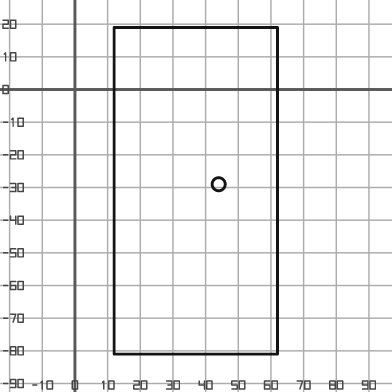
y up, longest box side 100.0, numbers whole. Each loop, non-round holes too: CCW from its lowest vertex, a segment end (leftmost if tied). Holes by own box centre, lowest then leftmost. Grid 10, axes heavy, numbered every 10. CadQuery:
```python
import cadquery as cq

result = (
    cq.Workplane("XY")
    .moveTo(12.0, -81.0)
    .lineTo(62.0, -81.0)
    .lineTo(62.0, 19.0)
    .lineTo(12.0, 19.0)
    .close()
    .moveTo(44.0, -29.0)
    .circle(2.0)
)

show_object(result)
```